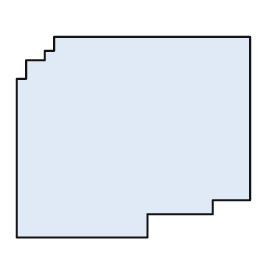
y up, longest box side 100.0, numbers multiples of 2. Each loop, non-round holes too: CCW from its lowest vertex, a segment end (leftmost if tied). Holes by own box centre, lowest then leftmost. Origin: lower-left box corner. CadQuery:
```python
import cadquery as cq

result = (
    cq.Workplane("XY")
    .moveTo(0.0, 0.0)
    .lineTo(56.0, 0.0)
    .lineTo(56.0, 10.0)
    .lineTo(84.0, 10.0)
    .lineTo(84.0, 16.0)
    .lineTo(100.0, 16.0)
    .lineTo(100.0, 86.0)
    .lineTo(16.0, 86.0)
    .lineTo(16.0, 80.0)
    .lineTo(12.0, 80.0)
    .lineTo(12.0, 76.0)
    .lineTo(4.0, 76.0)
    .lineTo(4.0, 68.0)
    .lineTo(0.0, 68.0)
    .close()
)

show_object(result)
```